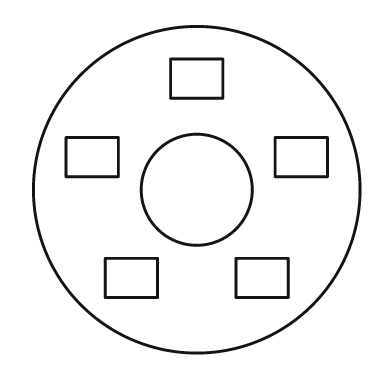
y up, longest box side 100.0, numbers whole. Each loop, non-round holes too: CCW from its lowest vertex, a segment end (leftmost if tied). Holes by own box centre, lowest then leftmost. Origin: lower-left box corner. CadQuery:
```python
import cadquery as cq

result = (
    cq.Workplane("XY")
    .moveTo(50.0, 50.0)
    .circle(50.0)
    .moveTo(22.0, 17.0)
    .lineTo(38.0, 17.0)
    .lineTo(38.0, 29.0)
    .lineTo(22.0, 29.0)
    .close()
    .moveTo(62.0, 17.0)
    .lineTo(78.0, 17.0)
    .lineTo(78.0, 29.0)
    .lineTo(62.0, 29.0)
    .close()
    .moveTo(50.0, 50.0)
    .circle(17.0)
    .moveTo(10.0, 54.0)
    .lineTo(26.0, 54.0)
    .lineTo(26.0, 66.0)
    .lineTo(10.0, 66.0)
    .close()
    .moveTo(74.0, 54.0)
    .lineTo(90.0, 54.0)
    .lineTo(90.0, 66.0)
    .lineTo(74.0, 66.0)
    .close()
    .moveTo(42.0, 78.0)
    .lineTo(58.0, 78.0)
    .lineTo(58.0, 90.0)
    .lineTo(42.0, 90.0)
    .close()
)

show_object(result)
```